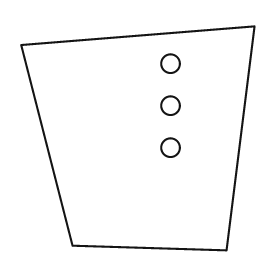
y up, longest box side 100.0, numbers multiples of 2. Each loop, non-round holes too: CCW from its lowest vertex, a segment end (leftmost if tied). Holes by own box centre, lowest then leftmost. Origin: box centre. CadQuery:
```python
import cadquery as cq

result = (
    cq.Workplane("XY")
    .moveTo(38.0, -48.0)
    .lineTo(50.0, 48.0)
    .lineTo(-50.0, 40.0)
    .lineTo(-28.0, -46.0)
    .close()
    .moveTo(14.0, -4.0)
    .circle(4.0)
    .moveTo(14.0, 14.0)
    .circle(4.0)
    .moveTo(14.0, 32.0)
    .circle(4.0)
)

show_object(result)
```